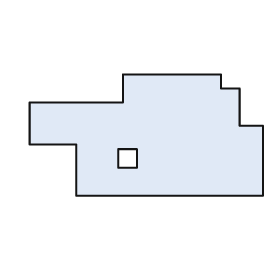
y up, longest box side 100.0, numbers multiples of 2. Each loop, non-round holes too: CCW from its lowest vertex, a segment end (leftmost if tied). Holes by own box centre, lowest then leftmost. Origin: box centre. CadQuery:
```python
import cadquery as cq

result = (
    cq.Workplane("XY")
    .moveTo(-30.0, -26.0)
    .lineTo(50.0, -26.0)
    .lineTo(50.0, 4.0)
    .lineTo(40.0, 4.0)
    .lineTo(40.0, 20.0)
    .lineTo(32.0, 20.0)
    .lineTo(32.0, 26.0)
    .lineTo(-10.0, 26.0)
    .lineTo(-10.0, 14.0)
    .lineTo(-50.0, 14.0)
    .lineTo(-50.0, -4.0)
    .lineTo(-30.0, -4.0)
    .close()
    .moveTo(-12.0, -14.0)
    .lineTo(-4.0, -14.0)
    .lineTo(-4.0, -6.0)
    .lineTo(-12.0, -6.0)
    .close()
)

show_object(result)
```